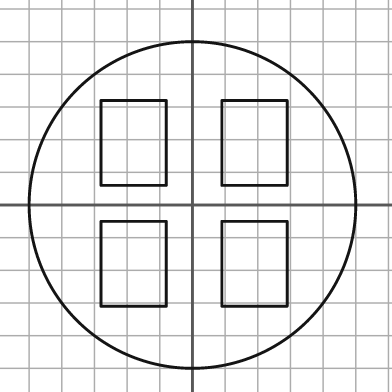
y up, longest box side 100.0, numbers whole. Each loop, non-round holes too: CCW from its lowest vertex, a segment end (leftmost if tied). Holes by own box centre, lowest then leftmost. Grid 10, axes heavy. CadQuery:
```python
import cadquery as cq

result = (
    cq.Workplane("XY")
    .moveTo(0.0, 0.0)
    .circle(50.0)
    .moveTo(-28.0, -31.0)
    .lineTo(-8.0, -31.0)
    .lineTo(-8.0, -5.0)
    .lineTo(-28.0, -5.0)
    .close()
    .moveTo(9.0, -31.0)
    .lineTo(29.0, -31.0)
    .lineTo(29.0, -5.0)
    .lineTo(9.0, -5.0)
    .close()
    .moveTo(-28.0, 6.0)
    .lineTo(-8.0, 6.0)
    .lineTo(-8.0, 32.0)
    .lineTo(-28.0, 32.0)
    .close()
    .moveTo(9.0, 6.0)
    .lineTo(29.0, 6.0)
    .lineTo(29.0, 32.0)
    .lineTo(9.0, 32.0)
    .close()
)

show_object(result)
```